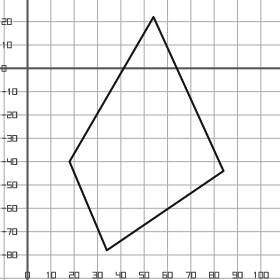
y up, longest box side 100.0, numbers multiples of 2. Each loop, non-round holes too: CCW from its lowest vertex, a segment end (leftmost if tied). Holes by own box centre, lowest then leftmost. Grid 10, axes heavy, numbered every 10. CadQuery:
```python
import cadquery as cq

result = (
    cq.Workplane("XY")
    .moveTo(34.0, -78.0)
    .lineTo(84.0, -44.0)
    .lineTo(54.0, 22.0)
    .lineTo(18.0, -40.0)
    .close()
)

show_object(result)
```